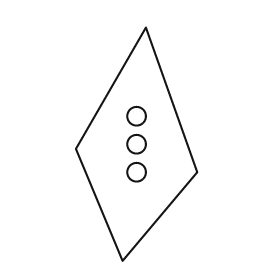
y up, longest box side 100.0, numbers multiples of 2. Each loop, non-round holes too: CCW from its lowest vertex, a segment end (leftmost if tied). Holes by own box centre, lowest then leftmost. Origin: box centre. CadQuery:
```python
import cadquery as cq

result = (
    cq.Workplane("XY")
    .moveTo(-6.0, -50.0)
    .lineTo(26.0, -12.0)
    .lineTo(4.0, 50.0)
    .lineTo(-26.0, -2.0)
    .close()
    .moveTo(0.0, -12.0)
    .circle(4.0)
    .moveTo(0.0, 0.0)
    .circle(4.0)
    .moveTo(0.0, 12.0)
    .circle(4.0)
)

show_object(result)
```